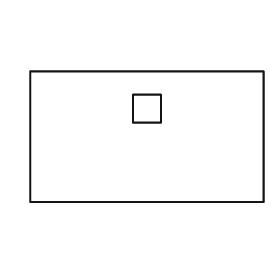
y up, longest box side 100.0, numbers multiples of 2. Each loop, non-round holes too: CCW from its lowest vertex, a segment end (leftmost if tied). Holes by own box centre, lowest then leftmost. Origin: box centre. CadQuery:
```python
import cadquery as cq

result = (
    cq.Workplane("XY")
    .moveTo(-50.0, -28.0)
    .lineTo(50.0, -28.0)
    .lineTo(50.0, 28.0)
    .lineTo(-50.0, 28.0)
    .close()
    .moveTo(-6.0, 6.0)
    .lineTo(6.0, 6.0)
    .lineTo(6.0, 18.0)
    .lineTo(-6.0, 18.0)
    .close()
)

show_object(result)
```